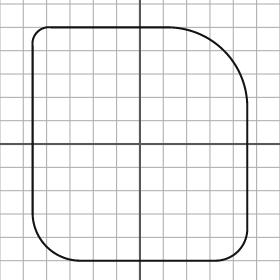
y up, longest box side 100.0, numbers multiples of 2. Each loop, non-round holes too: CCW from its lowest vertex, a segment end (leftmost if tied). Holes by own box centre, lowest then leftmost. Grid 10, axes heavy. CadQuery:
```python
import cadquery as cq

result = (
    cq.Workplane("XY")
    .moveTo(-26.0, -50.0)
    .lineTo(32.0, -50.0)
    .threePointArc((42.0, -46.0), (46.0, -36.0))
    .lineTo(46.0, 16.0)
    .threePointArc((36.0, 40.0), (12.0, 50.0))
    .lineTo(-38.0, 50.0)
    .threePointArc((-44.0, 48.0), (-46.0, 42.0))
    .lineTo(-46.0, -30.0)
    .threePointArc((-40.0, -44.0), (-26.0, -50.0))
    .close()
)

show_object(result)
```